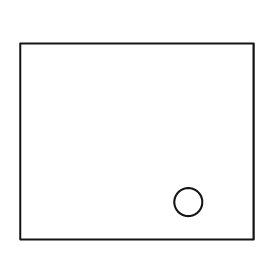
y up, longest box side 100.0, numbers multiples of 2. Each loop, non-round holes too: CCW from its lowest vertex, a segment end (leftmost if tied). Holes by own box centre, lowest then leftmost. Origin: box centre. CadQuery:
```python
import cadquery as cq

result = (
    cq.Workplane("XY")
    .moveTo(-50.0, -42.0)
    .lineTo(50.0, -42.0)
    .lineTo(50.0, 42.0)
    .lineTo(-50.0, 42.0)
    .close()
    .moveTo(22.0, -26.0)
    .circle(6.0)
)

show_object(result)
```